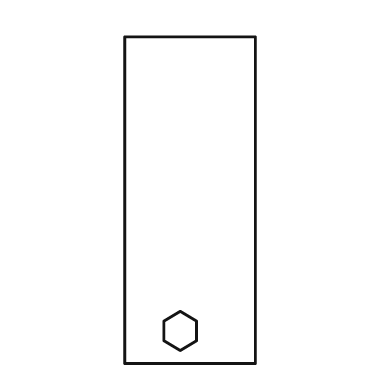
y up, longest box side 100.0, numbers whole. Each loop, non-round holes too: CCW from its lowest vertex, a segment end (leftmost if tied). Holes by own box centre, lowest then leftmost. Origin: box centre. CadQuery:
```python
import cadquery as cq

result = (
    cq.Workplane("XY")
    .moveTo(-20.0, -50.0)
    .lineTo(20.0, -50.0)
    .lineTo(20.0, 50.0)
    .lineTo(-20.0, 50.0)
    .close()
    .moveTo(-3.0, -46.0)
    .lineTo(2.0, -43.0)
    .lineTo(2.0, -37.0)
    .lineTo(-3.0, -34.0)
    .lineTo(-8.0, -37.0)
    .lineTo(-8.0, -43.0)
    .close()
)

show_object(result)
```